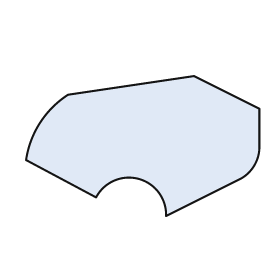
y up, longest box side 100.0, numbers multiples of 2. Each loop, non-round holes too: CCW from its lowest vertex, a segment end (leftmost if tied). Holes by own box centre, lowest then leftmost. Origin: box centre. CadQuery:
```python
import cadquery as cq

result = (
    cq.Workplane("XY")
    .moveTo(10.0, -30.0)
    .lineTo(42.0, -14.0)
    .threePointArc((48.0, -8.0), (50.0, 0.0))
    .lineTo(50.0, 16.0)
    .lineTo(22.0, 30.0)
    .lineTo(-32.0, 22.0)
    .threePointArc((-44.0, 10.0), (-50.0, -6.0))
    .lineTo(-20.0, -22.0)
    .threePointArc((-2.0, -14.0), (10.0, -30.0))
    .close()
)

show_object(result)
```